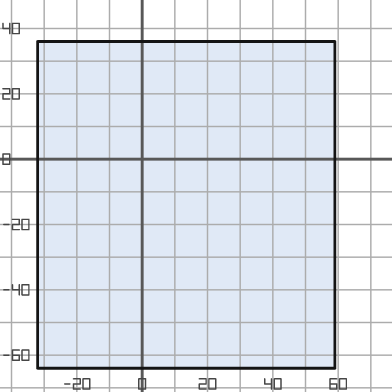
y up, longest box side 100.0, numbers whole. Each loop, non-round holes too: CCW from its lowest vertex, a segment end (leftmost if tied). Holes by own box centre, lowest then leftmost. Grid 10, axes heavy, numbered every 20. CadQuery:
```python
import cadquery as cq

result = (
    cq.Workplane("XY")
    .moveTo(-32.0, -64.0)
    .lineTo(59.0, -64.0)
    .lineTo(59.0, 36.0)
    .lineTo(-32.0, 36.0)
    .close()
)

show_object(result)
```